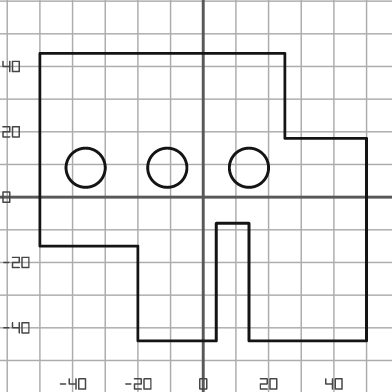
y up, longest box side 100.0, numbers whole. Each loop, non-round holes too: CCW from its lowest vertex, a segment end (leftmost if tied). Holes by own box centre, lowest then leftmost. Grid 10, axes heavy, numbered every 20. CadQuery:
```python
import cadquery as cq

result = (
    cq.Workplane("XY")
    .moveTo(-20.0, -44.0)
    .lineTo(4.0, -44.0)
    .lineTo(4.0, -8.0)
    .lineTo(14.0, -8.0)
    .lineTo(14.0, -44.0)
    .lineTo(50.0, -44.0)
    .lineTo(50.0, 18.0)
    .lineTo(25.0, 18.0)
    .lineTo(25.0, 44.0)
    .lineTo(-50.0, 44.0)
    .lineTo(-50.0, -15.0)
    .lineTo(-20.0, -15.0)
    .close()
    .moveTo(-36.0, 9.0)
    .circle(6.0)
    .moveTo(-11.0, 9.0)
    .circle(6.0)
    .moveTo(14.0, 9.0)
    .circle(6.0)
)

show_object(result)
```